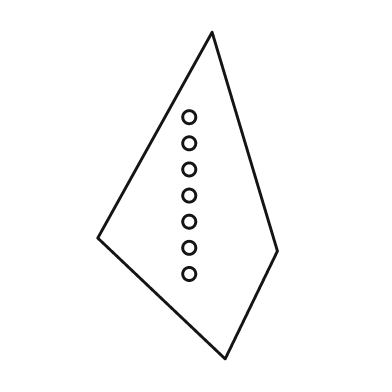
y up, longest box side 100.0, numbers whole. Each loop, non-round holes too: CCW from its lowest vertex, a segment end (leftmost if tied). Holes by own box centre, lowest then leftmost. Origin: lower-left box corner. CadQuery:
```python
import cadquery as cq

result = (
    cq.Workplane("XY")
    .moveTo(39.0, 0.0)
    .lineTo(55.0, 33.0)
    .lineTo(35.0, 100.0)
    .lineTo(0.0, 37.0)
    .close()
    .moveTo(28.0, 26.0)
    .circle(2.0)
    .moveTo(28.0, 34.0)
    .circle(2.0)
    .moveTo(28.0, 42.0)
    .circle(2.0)
    .moveTo(28.0, 50.0)
    .circle(2.0)
    .moveTo(28.0, 58.0)
    .circle(2.0)
    .moveTo(28.0, 66.0)
    .circle(2.0)
    .moveTo(28.0, 74.0)
    .circle(2.0)
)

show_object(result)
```